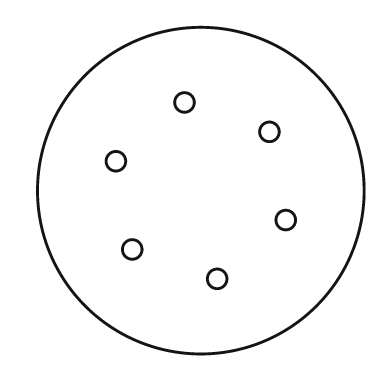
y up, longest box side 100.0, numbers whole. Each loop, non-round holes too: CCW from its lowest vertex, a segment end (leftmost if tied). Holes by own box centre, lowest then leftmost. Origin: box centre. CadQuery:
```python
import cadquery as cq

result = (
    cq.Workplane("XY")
    .moveTo(0.0, 0.0)
    .circle(50.0)
    .moveTo(5.0, -27.0)
    .circle(3.0)
    .moveTo(-21.0, -18.0)
    .circle(3.0)
    .moveTo(26.0, -9.0)
    .circle(3.0)
    .moveTo(-26.0, 9.0)
    .circle(3.0)
    .moveTo(21.0, 18.0)
    .circle(3.0)
    .moveTo(-5.0, 27.0)
    .circle(3.0)
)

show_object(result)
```